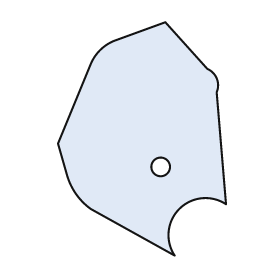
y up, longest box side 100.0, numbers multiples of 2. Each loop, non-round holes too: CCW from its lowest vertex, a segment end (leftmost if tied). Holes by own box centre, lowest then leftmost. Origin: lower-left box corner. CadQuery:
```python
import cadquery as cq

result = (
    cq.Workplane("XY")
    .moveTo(50.0, 0.0)
    .threePointArc((52.0, 20.0), (72.0, 22.0))
    .lineTo(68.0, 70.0)
    .threePointArc((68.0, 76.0), (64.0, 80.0))
    .lineTo(46.0, 100.0)
    .lineTo(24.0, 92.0)
    .threePointArc((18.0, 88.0), (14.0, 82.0))
    .lineTo(0.0, 48.0)
    .lineTo(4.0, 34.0)
    .threePointArc((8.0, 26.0), (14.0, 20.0))
    .close()
    .moveTo(44.0, 38.0)
    .circle(4.0)
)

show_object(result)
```